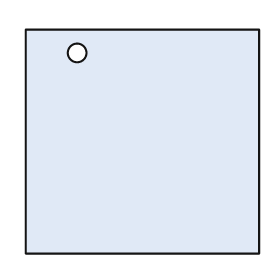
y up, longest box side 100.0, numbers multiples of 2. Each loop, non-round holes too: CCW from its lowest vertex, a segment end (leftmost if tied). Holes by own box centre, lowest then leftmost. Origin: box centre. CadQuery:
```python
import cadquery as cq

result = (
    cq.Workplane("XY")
    .moveTo(-50.0, -48.0)
    .lineTo(50.0, -48.0)
    .lineTo(50.0, 48.0)
    .lineTo(-50.0, 48.0)
    .close()
    .moveTo(-28.0, 38.0)
    .circle(4.0)
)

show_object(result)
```